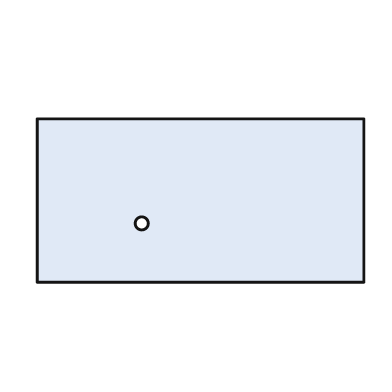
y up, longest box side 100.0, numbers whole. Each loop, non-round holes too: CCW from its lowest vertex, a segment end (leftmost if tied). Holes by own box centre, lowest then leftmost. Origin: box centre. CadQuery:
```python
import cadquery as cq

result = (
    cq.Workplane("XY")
    .moveTo(-50.0, -25.0)
    .lineTo(50.0, -25.0)
    .lineTo(50.0, 25.0)
    .lineTo(-50.0, 25.0)
    .close()
    .moveTo(-18.0, -7.0)
    .circle(2.0)
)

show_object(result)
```